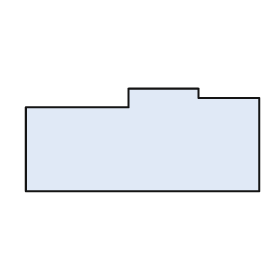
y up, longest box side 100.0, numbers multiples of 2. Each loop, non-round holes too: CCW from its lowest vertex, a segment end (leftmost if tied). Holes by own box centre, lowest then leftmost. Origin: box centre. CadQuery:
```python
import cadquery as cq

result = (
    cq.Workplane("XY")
    .moveTo(-50.0, -22.0)
    .lineTo(50.0, -22.0)
    .lineTo(50.0, 18.0)
    .lineTo(24.0, 18.0)
    .lineTo(24.0, 22.0)
    .lineTo(-6.0, 22.0)
    .lineTo(-6.0, 14.0)
    .lineTo(-50.0, 14.0)
    .close()
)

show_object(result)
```